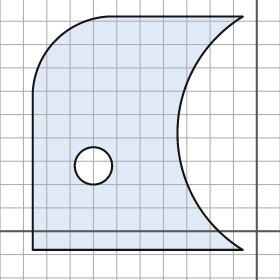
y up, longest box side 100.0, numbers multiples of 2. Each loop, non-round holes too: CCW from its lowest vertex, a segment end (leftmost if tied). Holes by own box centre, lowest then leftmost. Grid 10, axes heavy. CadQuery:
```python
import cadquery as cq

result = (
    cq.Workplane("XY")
    .moveTo(-96.0, -8.0)
    .lineTo(-6.0, -8.0)
    .threePointArc((-34.0, 42.0), (-6.0, 92.0))
    .lineTo(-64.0, 92.0)
    .threePointArc((-86.0, 82.0), (-96.0, 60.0))
    .close()
    .moveTo(-70.0, 28.0)
    .circle(8.0)
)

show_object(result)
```